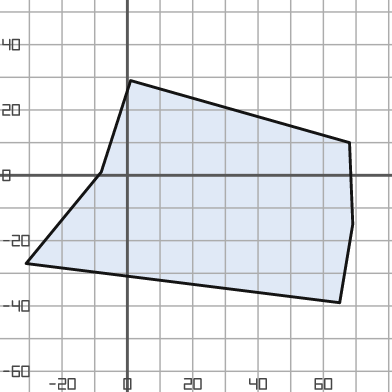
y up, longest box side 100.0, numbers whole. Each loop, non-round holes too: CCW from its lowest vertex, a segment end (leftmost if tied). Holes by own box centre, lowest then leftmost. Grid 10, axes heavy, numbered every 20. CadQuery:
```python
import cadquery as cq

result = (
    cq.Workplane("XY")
    .moveTo(65.0, -39.0)
    .lineTo(69.0, -15.0)
    .lineTo(68.0, 10.0)
    .lineTo(1.0, 29.0)
    .lineTo(-8.0, 1.0)
    .lineTo(-31.0, -27.0)
    .close()
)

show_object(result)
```